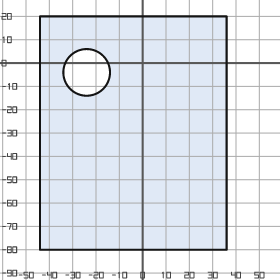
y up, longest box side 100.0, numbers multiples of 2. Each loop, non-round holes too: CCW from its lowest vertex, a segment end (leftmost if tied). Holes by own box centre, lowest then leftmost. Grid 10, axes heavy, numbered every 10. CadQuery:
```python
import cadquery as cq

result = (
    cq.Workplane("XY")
    .moveTo(-44.0, -80.0)
    .lineTo(36.0, -80.0)
    .lineTo(36.0, 20.0)
    .lineTo(-44.0, 20.0)
    .close()
    .moveTo(-24.0, -4.0)
    .circle(10.0)
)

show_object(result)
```